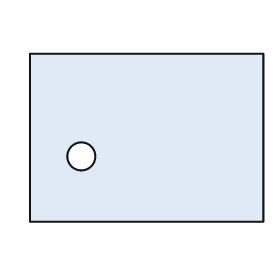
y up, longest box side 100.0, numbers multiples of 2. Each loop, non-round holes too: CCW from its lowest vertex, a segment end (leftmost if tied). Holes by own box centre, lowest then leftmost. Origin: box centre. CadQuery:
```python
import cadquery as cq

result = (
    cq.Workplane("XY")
    .moveTo(-50.0, -36.0)
    .lineTo(50.0, -36.0)
    .lineTo(50.0, 36.0)
    .lineTo(-50.0, 36.0)
    .close()
    .moveTo(-28.0, -8.0)
    .circle(6.0)
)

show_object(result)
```